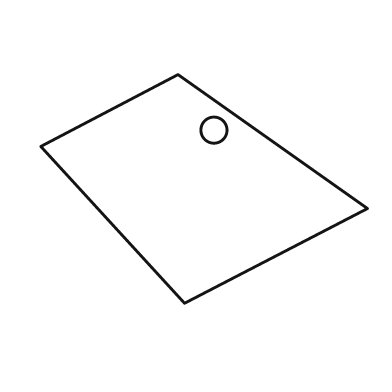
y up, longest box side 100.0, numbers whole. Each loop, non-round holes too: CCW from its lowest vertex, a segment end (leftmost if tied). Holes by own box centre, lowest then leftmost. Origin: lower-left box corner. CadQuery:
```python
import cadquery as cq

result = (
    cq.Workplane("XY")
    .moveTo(44.0, 0.0)
    .lineTo(100.0, 29.0)
    .lineTo(42.0, 70.0)
    .lineTo(0.0, 48.0)
    .close()
    .moveTo(53.0, 53.0)
    .circle(4.0)
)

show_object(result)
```